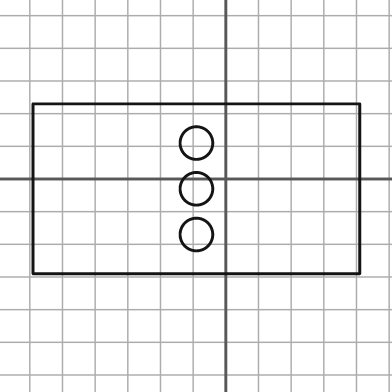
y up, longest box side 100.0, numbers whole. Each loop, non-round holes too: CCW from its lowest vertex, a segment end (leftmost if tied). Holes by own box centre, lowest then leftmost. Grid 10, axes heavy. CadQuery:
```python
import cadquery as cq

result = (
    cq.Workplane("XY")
    .moveTo(-59.0, -29.0)
    .lineTo(41.0, -29.0)
    .lineTo(41.0, 23.0)
    .lineTo(-59.0, 23.0)
    .close()
    .moveTo(-9.0, -17.0)
    .circle(5.0)
    .moveTo(-9.0, -3.0)
    .circle(5.0)
    .moveTo(-9.0, 11.0)
    .circle(5.0)
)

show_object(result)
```